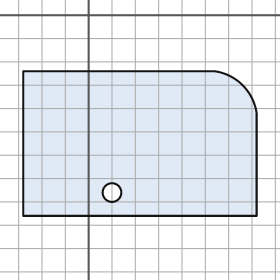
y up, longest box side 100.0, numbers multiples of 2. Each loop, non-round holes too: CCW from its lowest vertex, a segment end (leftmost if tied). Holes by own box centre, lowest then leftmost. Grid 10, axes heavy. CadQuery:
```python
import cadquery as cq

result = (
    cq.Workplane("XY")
    .moveTo(-28.0, -86.0)
    .lineTo(72.0, -86.0)
    .lineTo(72.0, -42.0)
    .threePointArc((66.0, -30.0), (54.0, -24.0))
    .lineTo(-28.0, -24.0)
    .close()
    .moveTo(10.0, -76.0)
    .circle(4.0)
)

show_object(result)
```